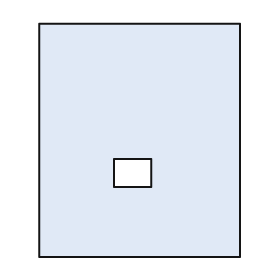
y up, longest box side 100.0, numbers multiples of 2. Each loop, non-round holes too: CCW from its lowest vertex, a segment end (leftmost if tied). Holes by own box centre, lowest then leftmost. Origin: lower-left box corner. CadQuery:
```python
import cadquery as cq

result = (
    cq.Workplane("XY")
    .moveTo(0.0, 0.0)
    .lineTo(86.0, 0.0)
    .lineTo(86.0, 100.0)
    .lineTo(0.0, 100.0)
    .close()
    .moveTo(32.0, 30.0)
    .lineTo(48.0, 30.0)
    .lineTo(48.0, 42.0)
    .lineTo(32.0, 42.0)
    .close()
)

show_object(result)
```